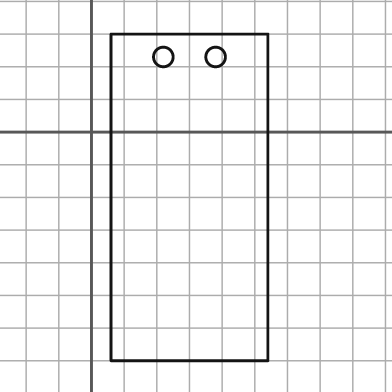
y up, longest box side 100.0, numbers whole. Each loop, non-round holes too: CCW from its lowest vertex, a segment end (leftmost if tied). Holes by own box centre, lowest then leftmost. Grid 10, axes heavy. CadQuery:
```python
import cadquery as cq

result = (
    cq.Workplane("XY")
    .moveTo(6.0, -70.0)
    .lineTo(54.0, -70.0)
    .lineTo(54.0, 30.0)
    .lineTo(6.0, 30.0)
    .close()
    .moveTo(22.0, 23.0)
    .circle(3.0)
    .moveTo(38.0, 23.0)
    .circle(3.0)
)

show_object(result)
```